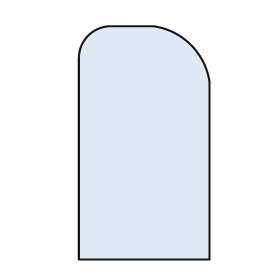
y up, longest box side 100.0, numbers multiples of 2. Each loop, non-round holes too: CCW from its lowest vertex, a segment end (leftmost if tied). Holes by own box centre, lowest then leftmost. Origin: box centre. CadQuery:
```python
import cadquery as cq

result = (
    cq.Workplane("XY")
    .moveTo(-28.0, -50.0)
    .lineTo(28.0, -50.0)
    .lineTo(28.0, 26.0)
    .threePointArc((20.0, 42.0), (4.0, 50.0))
    .lineTo(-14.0, 50.0)
    .threePointArc((-24.0, 46.0), (-28.0, 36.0))
    .close()
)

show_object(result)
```